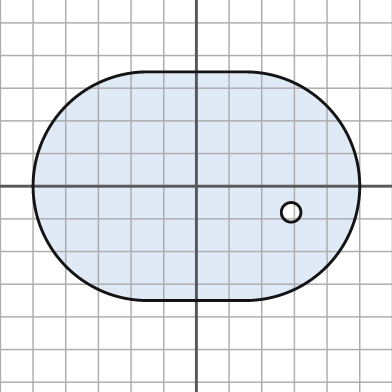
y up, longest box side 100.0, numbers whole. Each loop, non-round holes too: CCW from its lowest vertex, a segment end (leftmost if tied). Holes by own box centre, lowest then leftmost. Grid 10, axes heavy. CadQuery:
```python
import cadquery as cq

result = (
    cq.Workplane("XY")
    .moveTo(-15.0, -35.0)
    .lineTo(15.0, -35.0)
    .threePointArc((50.0, 0.0), (15.0, 35.0))
    .lineTo(-15.0, 35.0)
    .threePointArc((-50.0, 0.0), (-15.0, -35.0))
    .close()
    .moveTo(29.0, -8.0)
    .circle(3.0)
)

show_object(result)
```